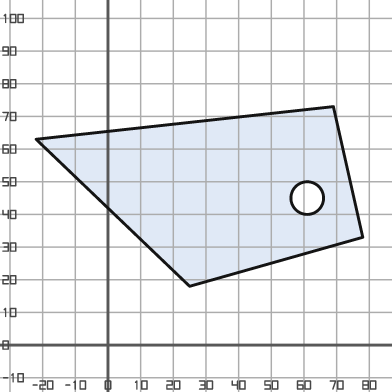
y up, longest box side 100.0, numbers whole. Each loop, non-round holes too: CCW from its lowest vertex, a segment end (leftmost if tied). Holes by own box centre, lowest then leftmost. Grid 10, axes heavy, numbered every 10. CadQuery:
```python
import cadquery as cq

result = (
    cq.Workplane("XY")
    .moveTo(25.0, 18.0)
    .lineTo(78.0, 33.0)
    .lineTo(69.0, 73.0)
    .lineTo(-22.0, 63.0)
    .close()
    .moveTo(61.0, 45.0)
    .circle(5.0)
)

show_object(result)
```